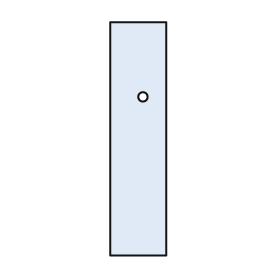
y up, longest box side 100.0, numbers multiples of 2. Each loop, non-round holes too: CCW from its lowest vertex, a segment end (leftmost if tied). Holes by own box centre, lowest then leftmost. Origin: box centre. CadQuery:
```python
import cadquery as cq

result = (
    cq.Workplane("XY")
    .moveTo(-12.0, -50.0)
    .lineTo(12.0, -50.0)
    .lineTo(12.0, 50.0)
    .lineTo(-12.0, 50.0)
    .close()
    .moveTo(2.0, 18.0)
    .circle(2.0)
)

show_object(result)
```